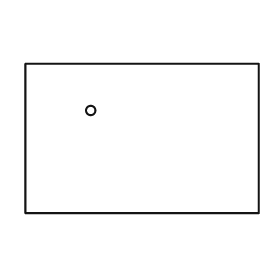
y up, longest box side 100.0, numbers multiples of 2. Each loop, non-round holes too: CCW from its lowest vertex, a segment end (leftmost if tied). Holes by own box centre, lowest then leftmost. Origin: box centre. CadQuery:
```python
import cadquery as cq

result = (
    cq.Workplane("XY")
    .moveTo(-50.0, -32.0)
    .lineTo(50.0, -32.0)
    .lineTo(50.0, 32.0)
    .lineTo(-50.0, 32.0)
    .close()
    .moveTo(-22.0, 12.0)
    .circle(2.0)
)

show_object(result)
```